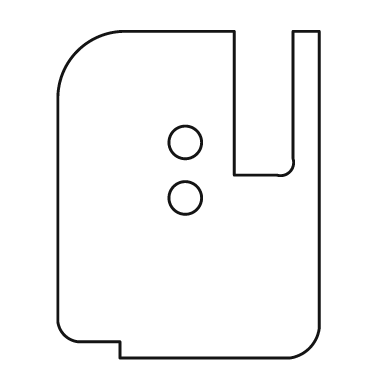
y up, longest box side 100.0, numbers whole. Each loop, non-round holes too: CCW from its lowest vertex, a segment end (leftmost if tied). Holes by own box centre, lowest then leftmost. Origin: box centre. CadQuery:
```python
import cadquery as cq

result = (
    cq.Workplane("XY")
    .moveTo(-21.0, -50.0)
    .lineTo(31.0, -50.0)
    .threePointArc((37.0, -47.0), (40.0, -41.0))
    .lineTo(40.0, 50.0)
    .lineTo(32.0, 50.0)
    .lineTo(32.0, 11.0)
    .threePointArc((31.0, 7.0), (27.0, 6.0))
    .lineTo(14.0, 6.0)
    .lineTo(14.0, 50.0)
    .lineTo(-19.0, 50.0)
    .threePointArc((-34.0, 44.0), (-40.0, 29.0))
    .lineTo(-40.0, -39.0)
    .threePointArc((-38.0, -43.0), (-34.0, -45.0))
    .lineTo(-21.0, -45.0)
    .close()
    .moveTo(-1.0, -1.0)
    .circle(5.0)
    .moveTo(-1.0, 16.0)
    .circle(5.0)
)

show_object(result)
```